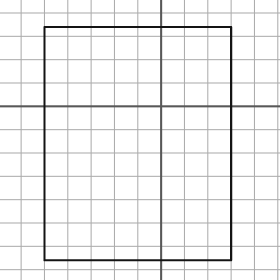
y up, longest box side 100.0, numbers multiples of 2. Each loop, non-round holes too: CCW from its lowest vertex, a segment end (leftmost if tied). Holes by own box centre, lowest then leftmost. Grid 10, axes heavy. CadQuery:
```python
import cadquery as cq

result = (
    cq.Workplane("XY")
    .moveTo(-50.0, -66.0)
    .lineTo(30.0, -66.0)
    .lineTo(30.0, 34.0)
    .lineTo(-50.0, 34.0)
    .close()
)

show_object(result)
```